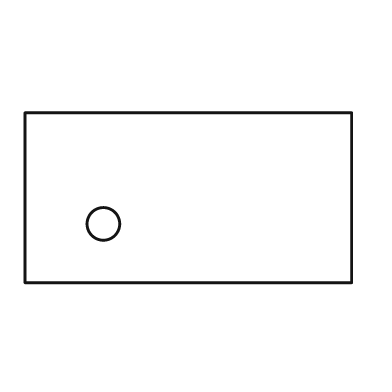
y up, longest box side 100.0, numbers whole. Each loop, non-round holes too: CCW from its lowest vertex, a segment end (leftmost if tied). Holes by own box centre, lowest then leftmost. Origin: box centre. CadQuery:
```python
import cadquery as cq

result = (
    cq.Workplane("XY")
    .moveTo(-50.0, -26.0)
    .lineTo(50.0, -26.0)
    .lineTo(50.0, 26.0)
    .lineTo(-50.0, 26.0)
    .close()
    .moveTo(-26.0, -8.0)
    .circle(5.0)
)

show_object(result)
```